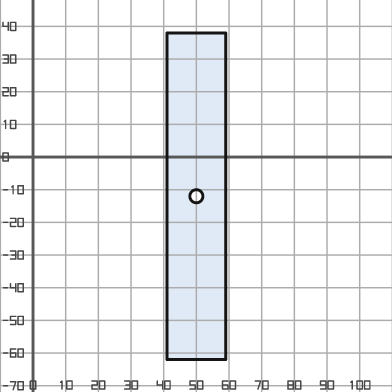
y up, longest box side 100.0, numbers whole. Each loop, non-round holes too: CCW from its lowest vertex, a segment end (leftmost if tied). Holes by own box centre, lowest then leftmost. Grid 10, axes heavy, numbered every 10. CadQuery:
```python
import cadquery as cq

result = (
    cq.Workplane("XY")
    .moveTo(41.0, -62.0)
    .lineTo(59.0, -62.0)
    .lineTo(59.0, 38.0)
    .lineTo(41.0, 38.0)
    .close()
    .moveTo(50.0, -12.0)
    .circle(2.0)
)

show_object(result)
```